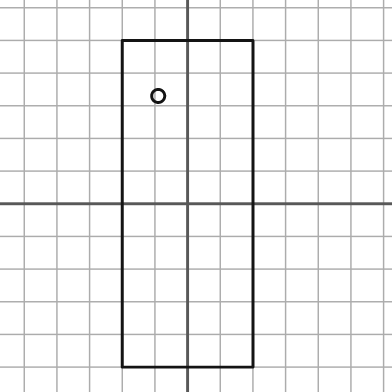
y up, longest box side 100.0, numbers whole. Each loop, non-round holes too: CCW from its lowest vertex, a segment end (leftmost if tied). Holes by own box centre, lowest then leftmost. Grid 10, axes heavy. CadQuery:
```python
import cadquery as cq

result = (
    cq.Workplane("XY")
    .moveTo(-20.0, -50.0)
    .lineTo(20.0, -50.0)
    .lineTo(20.0, 50.0)
    .lineTo(-20.0, 50.0)
    .close()
    .moveTo(-9.0, 33.0)
    .circle(2.0)
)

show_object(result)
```